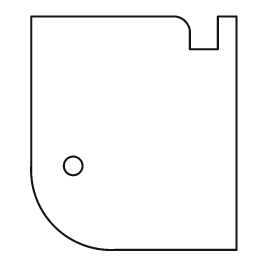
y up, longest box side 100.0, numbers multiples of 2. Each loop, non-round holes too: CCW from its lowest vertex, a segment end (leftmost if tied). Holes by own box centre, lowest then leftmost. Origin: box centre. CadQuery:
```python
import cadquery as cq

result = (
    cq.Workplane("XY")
    .moveTo(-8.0, -50.0)
    .lineTo(44.0, -50.0)
    .lineTo(44.0, 50.0)
    .lineTo(36.0, 50.0)
    .lineTo(36.0, 36.0)
    .lineTo(24.0, 36.0)
    .lineTo(24.0, 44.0)
    .threePointArc((22.0, 48.0), (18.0, 50.0))
    .lineTo(-44.0, 50.0)
    .lineTo(-44.0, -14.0)
    .threePointArc((-34.0, -40.0), (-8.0, -50.0))
    .close()
    .moveTo(-26.0, -14.0)
    .circle(4.0)
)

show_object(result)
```